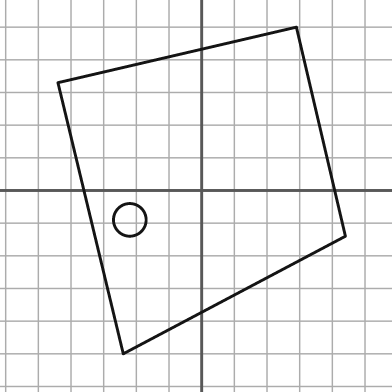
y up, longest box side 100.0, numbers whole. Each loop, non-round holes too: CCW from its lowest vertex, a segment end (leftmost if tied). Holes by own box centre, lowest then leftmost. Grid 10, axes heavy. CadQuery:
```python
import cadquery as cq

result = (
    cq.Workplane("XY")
    .moveTo(-24.0, -50.0)
    .lineTo(44.0, -14.0)
    .lineTo(29.0, 50.0)
    .lineTo(-44.0, 33.0)
    .close()
    .moveTo(-22.0, -9.0)
    .circle(5.0)
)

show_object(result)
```